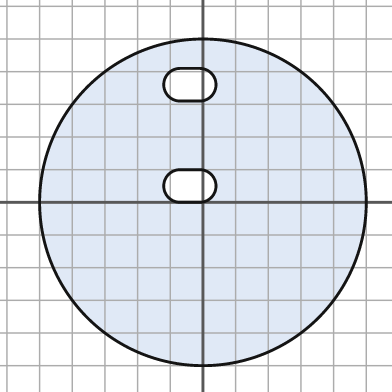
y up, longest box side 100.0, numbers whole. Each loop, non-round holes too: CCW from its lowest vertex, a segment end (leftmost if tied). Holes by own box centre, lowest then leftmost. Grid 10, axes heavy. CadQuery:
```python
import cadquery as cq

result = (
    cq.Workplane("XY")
    .moveTo(0.0, 0.0)
    .circle(50.0)
    .moveTo(-7.0, 0.0)
    .lineTo(-1.0, 0.0)
    .threePointArc((4.0, 5.0), (-1.0, 10.0))
    .lineTo(-7.0, 10.0)
    .threePointArc((-12.0, 5.0), (-7.0, 0.0))
    .close()
    .moveTo(-7.0, 31.0)
    .lineTo(-1.0, 31.0)
    .threePointArc((4.0, 36.0), (-1.0, 41.0))
    .lineTo(-7.0, 41.0)
    .threePointArc((-12.0, 36.0), (-7.0, 31.0))
    .close()
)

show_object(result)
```